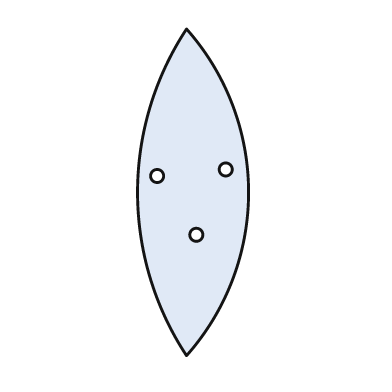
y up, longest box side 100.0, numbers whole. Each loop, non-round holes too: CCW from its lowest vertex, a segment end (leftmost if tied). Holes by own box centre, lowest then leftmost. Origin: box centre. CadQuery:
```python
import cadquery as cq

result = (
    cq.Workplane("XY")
    .moveTo(-2.0, -50.0)
    .threePointArc((17.0, 0.0), (-2.0, 50.0))
    .threePointArc((-17.0, 0.0), (-2.0, -50.0))
    .close()
    .moveTo(1.0, -13.0)
    .circle(2.0)
    .moveTo(-11.0, 5.0)
    .circle(2.0)
    .moveTo(10.0, 7.0)
    .circle(2.0)
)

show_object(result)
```